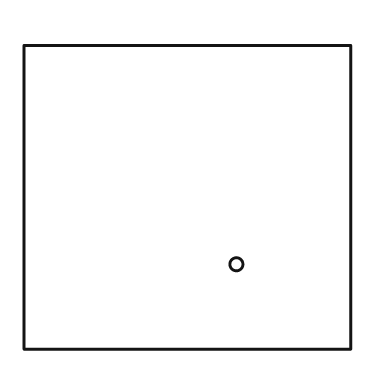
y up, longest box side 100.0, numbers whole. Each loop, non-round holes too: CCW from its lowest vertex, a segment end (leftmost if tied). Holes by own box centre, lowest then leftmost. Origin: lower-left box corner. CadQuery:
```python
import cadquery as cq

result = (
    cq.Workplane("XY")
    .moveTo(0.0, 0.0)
    .lineTo(100.0, 0.0)
    .lineTo(100.0, 93.0)
    .lineTo(0.0, 93.0)
    .close()
    .moveTo(65.0, 26.0)
    .circle(2.0)
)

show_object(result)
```